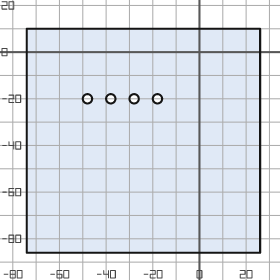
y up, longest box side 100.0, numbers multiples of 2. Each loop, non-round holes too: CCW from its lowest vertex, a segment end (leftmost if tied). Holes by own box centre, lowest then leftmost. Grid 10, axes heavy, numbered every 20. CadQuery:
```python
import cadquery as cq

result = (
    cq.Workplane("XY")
    .moveTo(-74.0, -86.0)
    .lineTo(26.0, -86.0)
    .lineTo(26.0, 10.0)
    .lineTo(-74.0, 10.0)
    .close()
    .moveTo(-48.0, -20.0)
    .circle(2.0)
    .moveTo(-38.0, -20.0)
    .circle(2.0)
    .moveTo(-28.0, -20.0)
    .circle(2.0)
    .moveTo(-18.0, -20.0)
    .circle(2.0)
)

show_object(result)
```